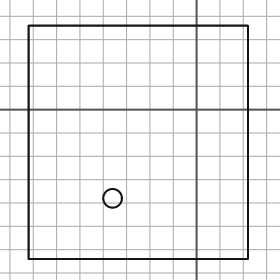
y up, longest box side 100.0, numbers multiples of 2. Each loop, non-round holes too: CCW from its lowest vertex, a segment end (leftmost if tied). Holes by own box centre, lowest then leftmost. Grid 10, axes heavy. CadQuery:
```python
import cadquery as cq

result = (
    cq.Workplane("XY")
    .moveTo(-72.0, -64.0)
    .lineTo(22.0, -64.0)
    .lineTo(22.0, 36.0)
    .lineTo(-72.0, 36.0)
    .close()
    .moveTo(-36.0, -38.0)
    .circle(4.0)
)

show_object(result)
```